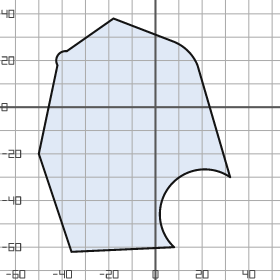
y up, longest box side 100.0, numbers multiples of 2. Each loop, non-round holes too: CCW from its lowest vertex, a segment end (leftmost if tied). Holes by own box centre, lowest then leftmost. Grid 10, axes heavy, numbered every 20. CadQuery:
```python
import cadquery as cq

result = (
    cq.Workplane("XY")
    .moveTo(-36.0, -62.0)
    .lineTo(8.0, -60.0)
    .threePointArc((6.0, -34.0), (32.0, -30.0))
    .lineTo(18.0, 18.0)
    .threePointArc((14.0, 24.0), (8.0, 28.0))
    .lineTo(-18.0, 38.0)
    .lineTo(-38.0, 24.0)
    .threePointArc((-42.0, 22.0), (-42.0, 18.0))
    .lineTo(-50.0, -20.0)
    .close()
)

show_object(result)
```